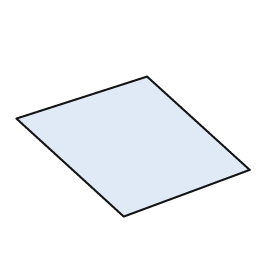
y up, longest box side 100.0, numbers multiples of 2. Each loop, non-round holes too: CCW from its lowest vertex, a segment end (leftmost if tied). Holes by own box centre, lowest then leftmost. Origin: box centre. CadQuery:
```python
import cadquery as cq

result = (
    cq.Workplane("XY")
    .moveTo(-4.0, -30.0)
    .lineTo(50.0, -10.0)
    .lineTo(6.0, 30.0)
    .lineTo(-50.0, 12.0)
    .close()
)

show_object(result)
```